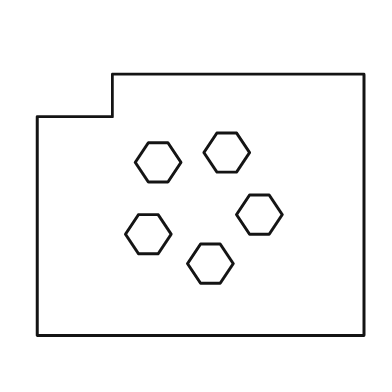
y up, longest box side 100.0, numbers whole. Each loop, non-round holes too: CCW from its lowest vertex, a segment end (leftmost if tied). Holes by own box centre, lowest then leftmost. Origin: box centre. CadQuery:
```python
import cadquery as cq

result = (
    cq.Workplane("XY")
    .moveTo(-50.0, -40.0)
    .lineTo(50.0, -40.0)
    .lineTo(50.0, 40.0)
    .lineTo(-27.0, 40.0)
    .lineTo(-27.0, 27.0)
    .lineTo(-50.0, 27.0)
    .close()
    .moveTo(0.0, -24.0)
    .lineTo(6.0, -24.0)
    .lineTo(10.0, -18.0)
    .lineTo(6.0, -12.0)
    .lineTo(0.0, -12.0)
    .lineTo(-4.0, -18.0)
    .close()
    .moveTo(-19.0, -15.0)
    .lineTo(-13.0, -15.0)
    .lineTo(-9.0, -9.0)
    .lineTo(-13.0, -3.0)
    .lineTo(-19.0, -3.0)
    .lineTo(-23.0, -9.0)
    .close()
    .moveTo(15.0, -9.0)
    .lineTo(21.0, -9.0)
    .lineTo(25.0, -3.0)
    .lineTo(21.0, 3.0)
    .lineTo(15.0, 3.0)
    .lineTo(11.0, -3.0)
    .close()
    .moveTo(-16.0, 7.0)
    .lineTo(-10.0, 7.0)
    .lineTo(-6.0, 13.0)
    .lineTo(-10.0, 19.0)
    .lineTo(-16.0, 19.0)
    .lineTo(-20.0, 13.0)
    .close()
    .moveTo(5.0, 10.0)
    .lineTo(11.0, 10.0)
    .lineTo(15.0, 16.0)
    .lineTo(11.0, 22.0)
    .lineTo(5.0, 22.0)
    .lineTo(1.0, 16.0)
    .close()
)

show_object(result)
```